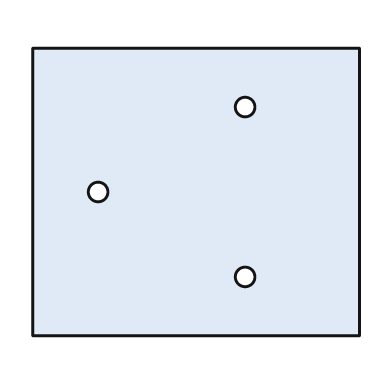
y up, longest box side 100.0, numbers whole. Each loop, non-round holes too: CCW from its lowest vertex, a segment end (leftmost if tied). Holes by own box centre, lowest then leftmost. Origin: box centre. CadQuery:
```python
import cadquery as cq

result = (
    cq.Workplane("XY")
    .moveTo(-50.0, -44.0)
    .lineTo(50.0, -44.0)
    .lineTo(50.0, 44.0)
    .lineTo(-50.0, 44.0)
    .close()
    .moveTo(15.0, -26.0)
    .circle(3.0)
    .moveTo(-30.0, 0.0)
    .circle(3.0)
    .moveTo(15.0, 26.0)
    .circle(3.0)
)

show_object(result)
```